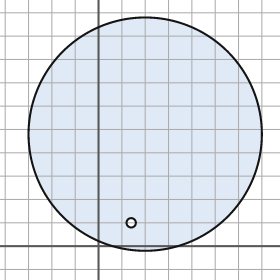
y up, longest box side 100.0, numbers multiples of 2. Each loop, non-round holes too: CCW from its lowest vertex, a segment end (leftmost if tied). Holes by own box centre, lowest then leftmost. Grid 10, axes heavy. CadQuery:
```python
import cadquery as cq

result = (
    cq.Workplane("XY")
    .moveTo(20.0, 48.0)
    .circle(50.0)
    .moveTo(14.0, 10.0)
    .circle(2.0)
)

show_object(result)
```